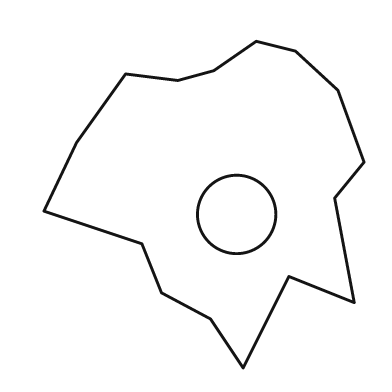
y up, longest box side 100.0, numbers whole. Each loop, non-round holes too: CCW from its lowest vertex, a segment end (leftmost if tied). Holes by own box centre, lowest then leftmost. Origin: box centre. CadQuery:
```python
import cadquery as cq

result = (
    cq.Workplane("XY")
    .moveTo(12.0, -50.0)
    .lineTo(26.0, -22.0)
    .lineTo(46.0, -30.0)
    .lineTo(40.0, 2.0)
    .lineTo(49.0, 13.0)
    .lineTo(41.0, 35.0)
    .lineTo(28.0, 47.0)
    .lineTo(16.0, 50.0)
    .lineTo(3.0, 41.0)
    .lineTo(-8.0, 38.0)
    .lineTo(-24.0, 40.0)
    .lineTo(-39.0, 19.0)
    .lineTo(-49.0, -2.0)
    .lineTo(-19.0, -12.0)
    .lineTo(-13.0, -27.0)
    .lineTo(2.0, -35.0)
    .close()
    .moveTo(10.0, -3.0)
    .circle(12.0)
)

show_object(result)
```